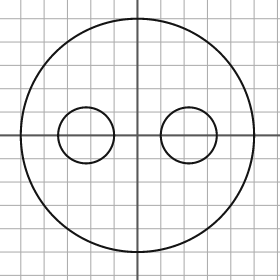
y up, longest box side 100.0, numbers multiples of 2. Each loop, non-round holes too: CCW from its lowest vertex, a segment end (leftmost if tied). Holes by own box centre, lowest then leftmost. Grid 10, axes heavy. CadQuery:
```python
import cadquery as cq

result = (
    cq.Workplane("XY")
    .moveTo(0.0, 0.0)
    .circle(50.0)
    .moveTo(-22.0, 0.0)
    .circle(12.0)
    .moveTo(22.0, 0.0)
    .circle(12.0)
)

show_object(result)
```